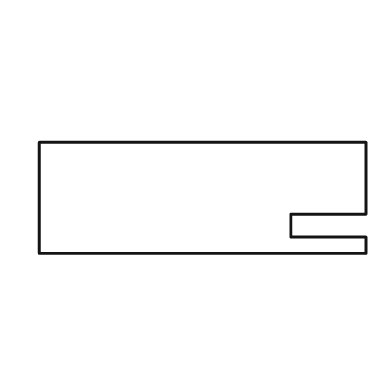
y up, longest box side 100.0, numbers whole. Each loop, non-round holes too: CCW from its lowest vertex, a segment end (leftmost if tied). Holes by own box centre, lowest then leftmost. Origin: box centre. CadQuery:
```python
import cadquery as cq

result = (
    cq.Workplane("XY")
    .moveTo(-50.0, -17.0)
    .lineTo(50.0, -17.0)
    .lineTo(50.0, -12.0)
    .lineTo(27.0, -12.0)
    .lineTo(27.0, -5.0)
    .lineTo(50.0, -5.0)
    .lineTo(50.0, 17.0)
    .lineTo(-50.0, 17.0)
    .close()
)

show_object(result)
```